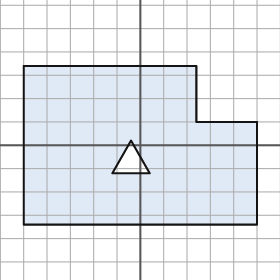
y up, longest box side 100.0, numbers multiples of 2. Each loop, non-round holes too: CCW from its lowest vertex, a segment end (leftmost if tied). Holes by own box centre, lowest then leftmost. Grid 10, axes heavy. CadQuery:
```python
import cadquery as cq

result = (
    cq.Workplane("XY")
    .moveTo(-50.0, -34.0)
    .lineTo(50.0, -34.0)
    .lineTo(50.0, 10.0)
    .lineTo(24.0, 10.0)
    .lineTo(24.0, 34.0)
    .lineTo(-50.0, 34.0)
    .close()
    .moveTo(-12.0, -12.0)
    .lineTo(4.0, -12.0)
    .lineTo(-4.0, 2.0)
    .close()
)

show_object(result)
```